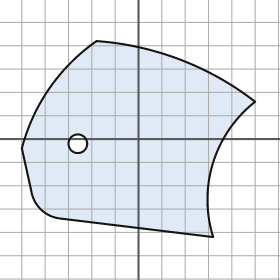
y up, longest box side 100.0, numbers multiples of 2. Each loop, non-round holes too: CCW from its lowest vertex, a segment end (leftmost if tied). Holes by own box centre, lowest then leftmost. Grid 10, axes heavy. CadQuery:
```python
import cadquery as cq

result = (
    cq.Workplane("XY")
    .moveTo(32.0, -42.0)
    .threePointArc((32.0, -10.0), (50.0, 16.0))
    .threePointArc((18.0, 34.0), (-18.0, 42.0))
    .threePointArc((-38.0, 22.0), (-50.0, -4.0))
    .lineTo(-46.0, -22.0)
    .threePointArc((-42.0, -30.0), (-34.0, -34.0))
    .close()
    .moveTo(-26.0, -2.0)
    .circle(4.0)
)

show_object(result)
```